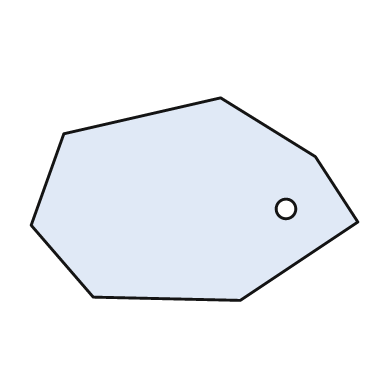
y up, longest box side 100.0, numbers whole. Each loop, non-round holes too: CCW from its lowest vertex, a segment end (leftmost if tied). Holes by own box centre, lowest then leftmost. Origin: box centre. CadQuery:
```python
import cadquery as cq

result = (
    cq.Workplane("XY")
    .moveTo(14.0, -31.0)
    .lineTo(50.0, -7.0)
    .lineTo(37.0, 13.0)
    .lineTo(8.0, 31.0)
    .lineTo(-40.0, 20.0)
    .lineTo(-50.0, -8.0)
    .lineTo(-31.0, -30.0)
    .close()
    .moveTo(28.0, -3.0)
    .circle(3.0)
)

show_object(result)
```